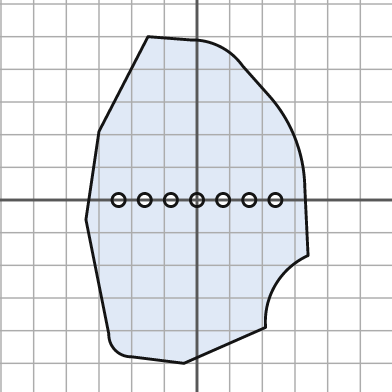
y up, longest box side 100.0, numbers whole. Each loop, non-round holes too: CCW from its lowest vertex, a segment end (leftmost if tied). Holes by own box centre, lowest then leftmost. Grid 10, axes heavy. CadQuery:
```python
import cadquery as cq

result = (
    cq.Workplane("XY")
    .moveTo(-4.0, -50.0)
    .lineTo(21.0, -39.0)
    .threePointArc((24.0, -26.0), (34.0, -17.0))
    .lineTo(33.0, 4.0)
    .threePointArc((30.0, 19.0), (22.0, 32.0))
    .lineTo(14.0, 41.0)
    .threePointArc((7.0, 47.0), (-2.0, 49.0))
    .lineTo(-15.0, 50.0)
    .lineTo(-30.0, 21.0)
    .lineTo(-34.0, -6.0)
    .lineTo(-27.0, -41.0)
    .threePointArc((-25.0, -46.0), (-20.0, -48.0))
    .close()
    .moveTo(-24.0, 0.0)
    .circle(2.0)
    .moveTo(-16.0, 0.0)
    .circle(2.0)
    .moveTo(-8.0, 0.0)
    .circle(2.0)
    .moveTo(0.0, 0.0)
    .circle(2.0)
    .moveTo(8.0, 0.0)
    .circle(2.0)
    .moveTo(16.0, 0.0)
    .circle(2.0)
    .moveTo(24.0, 0.0)
    .circle(2.0)
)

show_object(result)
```